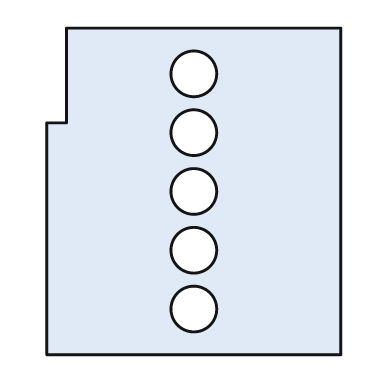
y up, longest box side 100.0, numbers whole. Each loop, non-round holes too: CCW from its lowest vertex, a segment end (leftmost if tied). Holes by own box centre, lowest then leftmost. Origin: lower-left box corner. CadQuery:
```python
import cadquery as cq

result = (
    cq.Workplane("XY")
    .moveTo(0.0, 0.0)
    .lineTo(90.0, 0.0)
    .lineTo(90.0, 100.0)
    .lineTo(6.0, 100.0)
    .lineTo(6.0, 71.0)
    .lineTo(0.0, 71.0)
    .close()
    .moveTo(45.0, 14.0)
    .circle(7.0)
    .moveTo(45.0, 32.0)
    .circle(7.0)
    .moveTo(45.0, 50.0)
    .circle(7.0)
    .moveTo(45.0, 68.0)
    .circle(7.0)
    .moveTo(45.0, 86.0)
    .circle(7.0)
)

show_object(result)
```